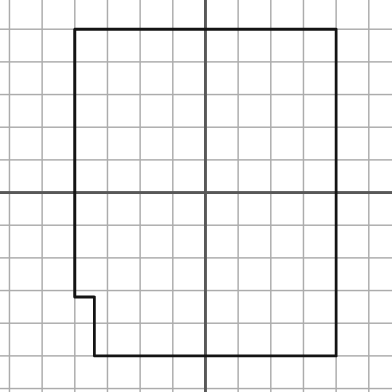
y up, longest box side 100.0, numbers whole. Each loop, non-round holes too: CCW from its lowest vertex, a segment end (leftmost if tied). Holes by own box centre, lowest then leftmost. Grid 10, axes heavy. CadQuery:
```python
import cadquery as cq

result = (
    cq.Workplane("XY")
    .moveTo(-34.0, -50.0)
    .lineTo(40.0, -50.0)
    .lineTo(40.0, 50.0)
    .lineTo(-40.0, 50.0)
    .lineTo(-40.0, -32.0)
    .lineTo(-34.0, -32.0)
    .close()
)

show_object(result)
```